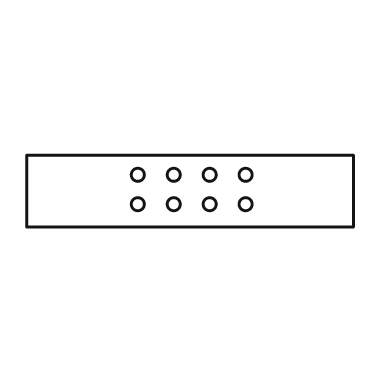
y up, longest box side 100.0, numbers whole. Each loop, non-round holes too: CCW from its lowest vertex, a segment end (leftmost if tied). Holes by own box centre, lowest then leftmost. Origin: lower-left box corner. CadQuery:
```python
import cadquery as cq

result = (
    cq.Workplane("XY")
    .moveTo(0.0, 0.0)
    .lineTo(100.0, 0.0)
    .lineTo(100.0, 22.0)
    .lineTo(0.0, 22.0)
    .close()
    .moveTo(34.0, 7.0)
    .circle(2.0)
    .moveTo(45.0, 7.0)
    .circle(2.0)
    .moveTo(56.0, 7.0)
    .circle(2.0)
    .moveTo(67.0, 7.0)
    .circle(2.0)
    .moveTo(34.0, 16.0)
    .circle(2.0)
    .moveTo(45.0, 16.0)
    .circle(2.0)
    .moveTo(56.0, 16.0)
    .circle(2.0)
    .moveTo(67.0, 16.0)
    .circle(2.0)
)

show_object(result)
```